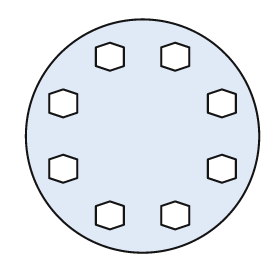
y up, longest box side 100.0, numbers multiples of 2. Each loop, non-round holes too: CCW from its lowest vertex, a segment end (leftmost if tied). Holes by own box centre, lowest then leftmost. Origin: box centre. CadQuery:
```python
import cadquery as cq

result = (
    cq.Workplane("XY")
    .moveTo(0.0, 0.0)
    .circle(50.0)
    .moveTo(-14.0, -40.0)
    .lineTo(-8.0, -38.0)
    .lineTo(-8.0, -30.0)
    .lineTo(-14.0, -28.0)
    .lineTo(-20.0, -30.0)
    .lineTo(-20.0, -38.0)
    .close()
    .moveTo(14.0, -40.0)
    .lineTo(20.0, -38.0)
    .lineTo(20.0, -30.0)
    .lineTo(14.0, -28.0)
    .lineTo(8.0, -30.0)
    .lineTo(8.0, -38.0)
    .close()
    .moveTo(-34.0, -20.0)
    .lineTo(-28.0, -18.0)
    .lineTo(-28.0, -10.0)
    .lineTo(-34.0, -8.0)
    .lineTo(-40.0, -10.0)
    .lineTo(-40.0, -18.0)
    .close()
    .moveTo(34.0, -20.0)
    .lineTo(40.0, -18.0)
    .lineTo(40.0, -10.0)
    .lineTo(34.0, -8.0)
    .lineTo(28.0, -10.0)
    .lineTo(28.0, -18.0)
    .close()
    .moveTo(-34.0, 8.0)
    .lineTo(-28.0, 10.0)
    .lineTo(-28.0, 18.0)
    .lineTo(-34.0, 20.0)
    .lineTo(-40.0, 18.0)
    .lineTo(-40.0, 10.0)
    .close()
    .moveTo(34.0, 8.0)
    .lineTo(40.0, 10.0)
    .lineTo(40.0, 18.0)
    .lineTo(34.0, 20.0)
    .lineTo(28.0, 18.0)
    .lineTo(28.0, 10.0)
    .close()
    .moveTo(-14.0, 28.0)
    .lineTo(-8.0, 30.0)
    .lineTo(-8.0, 38.0)
    .lineTo(-14.0, 40.0)
    .lineTo(-20.0, 38.0)
    .lineTo(-20.0, 30.0)
    .close()
    .moveTo(14.0, 28.0)
    .lineTo(20.0, 30.0)
    .lineTo(20.0, 38.0)
    .lineTo(14.0, 40.0)
    .lineTo(8.0, 38.0)
    .lineTo(8.0, 30.0)
    .close()
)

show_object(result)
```